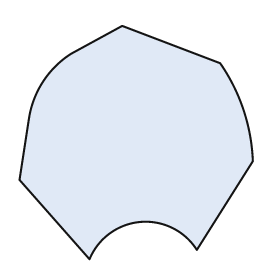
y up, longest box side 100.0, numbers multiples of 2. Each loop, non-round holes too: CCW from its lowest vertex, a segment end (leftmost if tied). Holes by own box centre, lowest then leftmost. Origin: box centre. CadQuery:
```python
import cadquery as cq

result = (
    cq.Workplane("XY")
    .moveTo(-20.0, -50.0)
    .threePointArc((2.0, -34.0), (26.0, -46.0))
    .lineTo(50.0, -8.0)
    .threePointArc((46.0, 14.0), (36.0, 34.0))
    .lineTo(-6.0, 50.0)
    .lineTo(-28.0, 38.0)
    .threePointArc((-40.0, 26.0), (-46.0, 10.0))
    .lineTo(-50.0, -16.0)
    .close()
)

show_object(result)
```